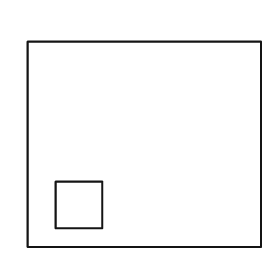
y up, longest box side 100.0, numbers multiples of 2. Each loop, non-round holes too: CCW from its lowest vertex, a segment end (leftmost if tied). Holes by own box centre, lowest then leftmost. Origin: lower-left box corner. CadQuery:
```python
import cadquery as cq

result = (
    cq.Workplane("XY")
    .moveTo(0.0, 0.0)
    .lineTo(100.0, 0.0)
    .lineTo(100.0, 88.0)
    .lineTo(0.0, 88.0)
    .close()
    .moveTo(12.0, 8.0)
    .lineTo(32.0, 8.0)
    .lineTo(32.0, 28.0)
    .lineTo(12.0, 28.0)
    .close()
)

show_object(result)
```